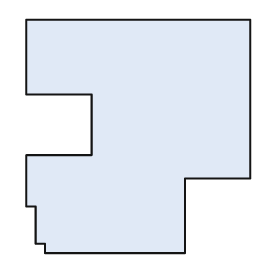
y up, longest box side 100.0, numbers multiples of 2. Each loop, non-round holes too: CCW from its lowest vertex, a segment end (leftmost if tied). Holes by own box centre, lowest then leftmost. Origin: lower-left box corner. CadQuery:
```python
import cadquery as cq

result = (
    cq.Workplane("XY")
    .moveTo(8.0, 0.0)
    .lineTo(68.0, 0.0)
    .lineTo(68.0, 32.0)
    .lineTo(96.0, 32.0)
    .lineTo(96.0, 100.0)
    .lineTo(0.0, 100.0)
    .lineTo(0.0, 68.0)
    .lineTo(28.0, 68.0)
    .lineTo(28.0, 42.0)
    .lineTo(0.0, 42.0)
    .lineTo(0.0, 20.0)
    .lineTo(4.0, 20.0)
    .lineTo(4.0, 4.0)
    .lineTo(8.0, 4.0)
    .close()
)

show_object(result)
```